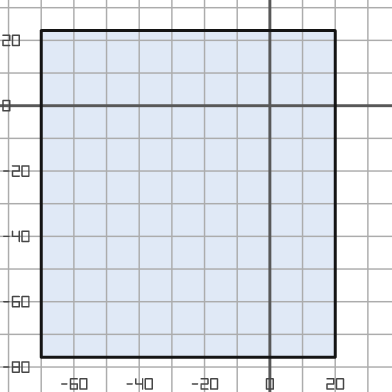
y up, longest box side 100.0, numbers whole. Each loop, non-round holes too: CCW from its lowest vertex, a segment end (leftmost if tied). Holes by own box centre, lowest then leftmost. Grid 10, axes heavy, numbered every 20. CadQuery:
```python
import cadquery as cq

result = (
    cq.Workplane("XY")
    .moveTo(-70.0, -77.0)
    .lineTo(20.0, -77.0)
    .lineTo(20.0, 23.0)
    .lineTo(-70.0, 23.0)
    .close()
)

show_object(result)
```